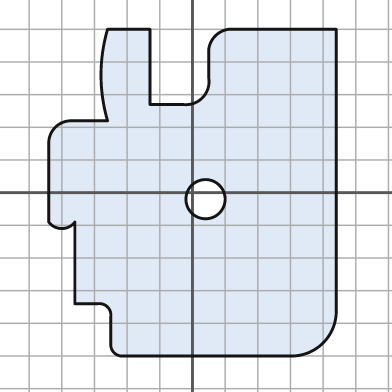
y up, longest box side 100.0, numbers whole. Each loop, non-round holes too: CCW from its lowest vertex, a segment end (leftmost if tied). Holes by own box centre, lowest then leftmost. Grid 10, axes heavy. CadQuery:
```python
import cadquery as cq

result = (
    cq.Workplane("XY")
    .moveTo(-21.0, -50.0)
    .lineTo(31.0, -50.0)
    .threePointArc((40.0, -46.0), (44.0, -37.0))
    .lineTo(44.0, 50.0)
    .lineTo(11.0, 50.0)
    .threePointArc((7.0, 48.0), (5.0, 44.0))
    .lineTo(5.0, 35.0)
    .threePointArc((3.0, 29.0), (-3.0, 27.0))
    .lineTo(-13.0, 27.0)
    .lineTo(-13.0, 50.0)
    .lineTo(-26.0, 50.0)
    .threePointArc((-28.0, 36.0), (-26.0, 22.0))
    .lineTo(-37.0, 22.0)
    .threePointArc((-42.0, 20.0), (-44.0, 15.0))
    .lineTo(-44.0, -9.0)
    .threePointArc((-40.0, -11.0), (-36.0, -9.0))
    .lineTo(-36.0, -34.0)
    .lineTo(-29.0, -34.0)
    .threePointArc((-26.0, -35.0), (-25.0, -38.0))
    .lineTo(-25.0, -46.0)
    .threePointArc((-24.0, -49.0), (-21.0, -50.0))
    .close()
    .moveTo(4.0, -2.0)
    .circle(6.0)
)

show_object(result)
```